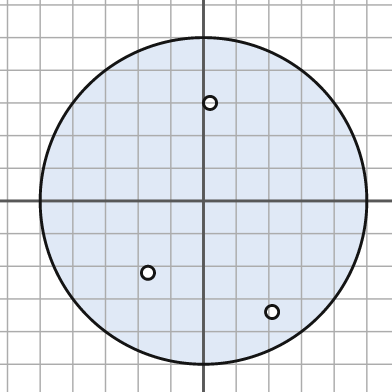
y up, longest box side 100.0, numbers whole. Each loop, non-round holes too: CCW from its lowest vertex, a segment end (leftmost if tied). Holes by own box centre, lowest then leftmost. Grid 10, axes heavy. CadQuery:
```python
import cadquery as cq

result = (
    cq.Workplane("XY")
    .moveTo(0.0, 0.0)
    .circle(50.0)
    .moveTo(21.0, -34.0)
    .circle(2.0)
    .moveTo(-17.0, -22.0)
    .circle(2.0)
    .moveTo(2.0, 30.0)
    .circle(2.0)
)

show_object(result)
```